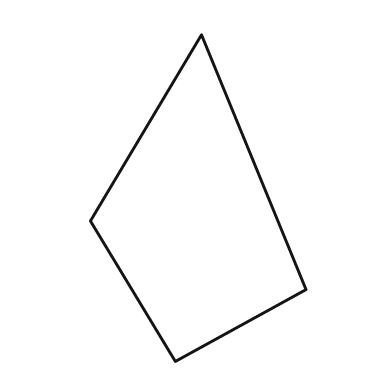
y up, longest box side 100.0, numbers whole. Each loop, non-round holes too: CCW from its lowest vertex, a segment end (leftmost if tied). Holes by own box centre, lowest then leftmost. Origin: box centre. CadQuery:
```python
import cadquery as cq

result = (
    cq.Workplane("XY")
    .moveTo(-7.0, -50.0)
    .lineTo(33.0, -28.0)
    .lineTo(1.0, 50.0)
    .lineTo(-33.0, -7.0)
    .close()
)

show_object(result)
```